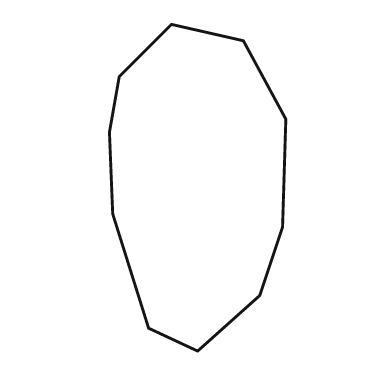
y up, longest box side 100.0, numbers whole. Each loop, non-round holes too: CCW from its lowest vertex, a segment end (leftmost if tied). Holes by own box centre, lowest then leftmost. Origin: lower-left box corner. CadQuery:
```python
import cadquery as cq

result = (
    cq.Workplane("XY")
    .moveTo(27.0, 0.0)
    .lineTo(46.0, 17.0)
    .lineTo(53.0, 38.0)
    .lineTo(54.0, 71.0)
    .lineTo(41.0, 95.0)
    .lineTo(19.0, 100.0)
    .lineTo(3.0, 84.0)
    .lineTo(0.0, 67.0)
    .lineTo(1.0, 42.0)
    .lineTo(12.0, 7.0)
    .close()
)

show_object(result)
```